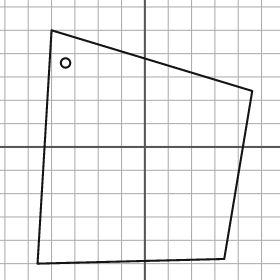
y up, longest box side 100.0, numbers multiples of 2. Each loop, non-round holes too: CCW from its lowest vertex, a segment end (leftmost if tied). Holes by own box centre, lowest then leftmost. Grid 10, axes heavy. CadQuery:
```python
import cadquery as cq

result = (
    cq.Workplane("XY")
    .moveTo(-46.0, -50.0)
    .lineTo(34.0, -48.0)
    .lineTo(46.0, 24.0)
    .lineTo(-40.0, 50.0)
    .close()
    .moveTo(-34.0, 36.0)
    .circle(2.0)
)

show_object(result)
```